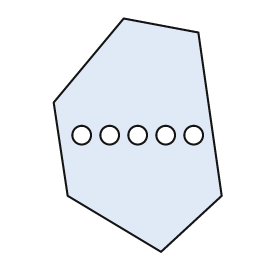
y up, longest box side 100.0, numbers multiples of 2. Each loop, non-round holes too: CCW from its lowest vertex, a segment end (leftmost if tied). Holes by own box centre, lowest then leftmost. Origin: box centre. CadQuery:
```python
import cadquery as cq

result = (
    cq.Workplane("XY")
    .moveTo(10.0, -50.0)
    .lineTo(36.0, -26.0)
    .lineTo(26.0, 44.0)
    .lineTo(-6.0, 50.0)
    .lineTo(-36.0, 14.0)
    .lineTo(-30.0, -26.0)
    .close()
    .moveTo(-24.0, 0.0)
    .circle(4.0)
    .moveTo(-12.0, 0.0)
    .circle(4.0)
    .moveTo(0.0, 0.0)
    .circle(4.0)
    .moveTo(12.0, 0.0)
    .circle(4.0)
    .moveTo(24.0, 0.0)
    .circle(4.0)
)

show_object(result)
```